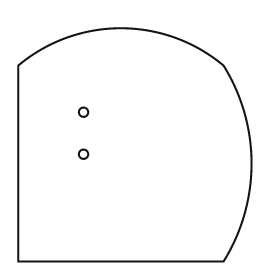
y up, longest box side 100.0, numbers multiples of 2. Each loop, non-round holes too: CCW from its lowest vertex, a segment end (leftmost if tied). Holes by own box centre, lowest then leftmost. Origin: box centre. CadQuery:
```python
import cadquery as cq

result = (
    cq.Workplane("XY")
    .moveTo(-50.0, -50.0)
    .lineTo(38.0, -50.0)
    .threePointArc((50.0, -8.0), (38.0, 34.0))
    .threePointArc((-6.0, 50.0), (-50.0, 34.0))
    .close()
    .moveTo(-22.0, -4.0)
    .circle(2.0)
    .moveTo(-22.0, 14.0)
    .circle(2.0)
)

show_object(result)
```